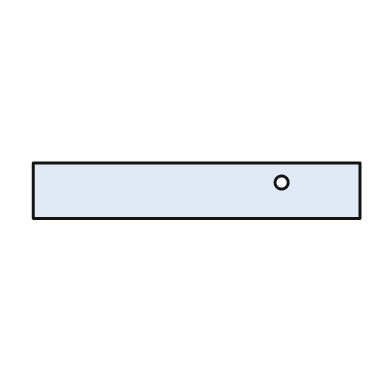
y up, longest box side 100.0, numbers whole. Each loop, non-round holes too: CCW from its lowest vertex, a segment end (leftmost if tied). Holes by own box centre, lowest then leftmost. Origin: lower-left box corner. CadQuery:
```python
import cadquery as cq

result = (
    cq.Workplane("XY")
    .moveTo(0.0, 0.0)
    .lineTo(100.0, 0.0)
    .lineTo(100.0, 17.0)
    .lineTo(0.0, 17.0)
    .close()
    .moveTo(76.0, 11.0)
    .circle(2.0)
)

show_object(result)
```